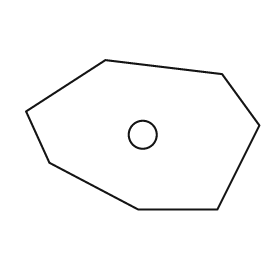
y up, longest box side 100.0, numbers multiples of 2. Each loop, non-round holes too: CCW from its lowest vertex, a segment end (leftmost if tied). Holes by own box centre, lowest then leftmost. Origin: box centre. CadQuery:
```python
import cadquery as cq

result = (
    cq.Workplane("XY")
    .moveTo(-2.0, -32.0)
    .lineTo(32.0, -32.0)
    .lineTo(50.0, 4.0)
    .lineTo(34.0, 26.0)
    .lineTo(-16.0, 32.0)
    .lineTo(-50.0, 10.0)
    .lineTo(-40.0, -12.0)
    .close()
    .moveTo(0.0, 0.0)
    .circle(6.0)
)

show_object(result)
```